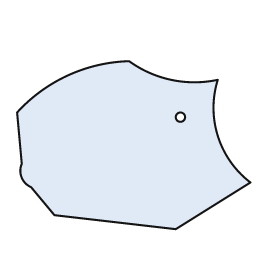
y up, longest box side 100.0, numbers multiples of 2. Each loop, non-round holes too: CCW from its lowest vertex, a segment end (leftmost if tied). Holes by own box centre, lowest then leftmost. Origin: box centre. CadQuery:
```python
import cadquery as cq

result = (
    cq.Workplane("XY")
    .moveTo(18.0, -36.0)
    .lineTo(50.0, -16.0)
    .threePointArc((36.0, 4.0), (36.0, 28.0))
    .threePointArc((16.0, 28.0), (-2.0, 36.0))
    .threePointArc((-28.0, 30.0), (-50.0, 14.0))
    .lineTo(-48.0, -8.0)
    .threePointArc((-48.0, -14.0), (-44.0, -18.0))
    .lineTo(-34.0, -30.0)
    .close()
    .moveTo(20.0, 12.0)
    .circle(2.0)
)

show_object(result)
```